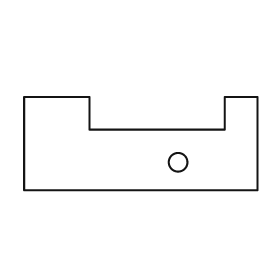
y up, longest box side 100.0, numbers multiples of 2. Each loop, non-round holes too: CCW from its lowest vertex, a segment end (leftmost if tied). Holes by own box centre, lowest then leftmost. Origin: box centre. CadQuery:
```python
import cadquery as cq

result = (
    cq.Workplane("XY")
    .moveTo(-50.0, -20.0)
    .lineTo(50.0, -20.0)
    .lineTo(50.0, 20.0)
    .lineTo(36.0, 20.0)
    .lineTo(36.0, 6.0)
    .lineTo(-22.0, 6.0)
    .lineTo(-22.0, 20.0)
    .lineTo(-50.0, 20.0)
    .close()
    .moveTo(16.0, -8.0)
    .circle(4.0)
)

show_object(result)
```